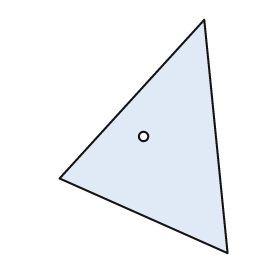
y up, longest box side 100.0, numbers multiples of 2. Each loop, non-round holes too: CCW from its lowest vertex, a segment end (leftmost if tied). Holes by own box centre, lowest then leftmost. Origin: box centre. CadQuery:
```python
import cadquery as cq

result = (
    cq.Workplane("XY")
    .moveTo(36.0, -50.0)
    .lineTo(26.0, 50.0)
    .lineTo(-36.0, -18.0)
    .close()
    .moveTo(0.0, 0.0)
    .circle(2.0)
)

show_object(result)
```